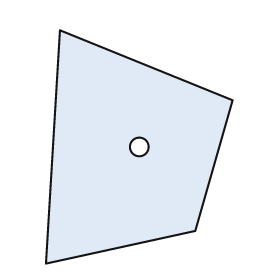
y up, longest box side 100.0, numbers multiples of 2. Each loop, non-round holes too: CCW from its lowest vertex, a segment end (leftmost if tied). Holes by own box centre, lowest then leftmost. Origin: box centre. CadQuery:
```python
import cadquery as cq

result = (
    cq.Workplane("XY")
    .moveTo(-40.0, -50.0)
    .lineTo(24.0, -36.0)
    .lineTo(40.0, 20.0)
    .lineTo(-34.0, 50.0)
    .close()
    .moveTo(0.0, 0.0)
    .circle(4.0)
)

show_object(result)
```